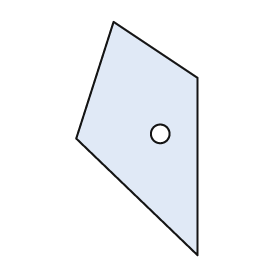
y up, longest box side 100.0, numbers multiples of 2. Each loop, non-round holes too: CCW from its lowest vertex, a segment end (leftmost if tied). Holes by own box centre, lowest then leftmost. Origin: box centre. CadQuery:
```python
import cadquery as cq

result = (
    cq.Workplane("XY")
    .moveTo(26.0, -50.0)
    .lineTo(26.0, 26.0)
    .lineTo(-10.0, 50.0)
    .lineTo(-26.0, 0.0)
    .close()
    .moveTo(10.0, 2.0)
    .circle(4.0)
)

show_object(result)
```